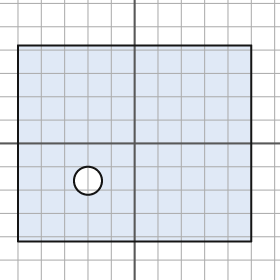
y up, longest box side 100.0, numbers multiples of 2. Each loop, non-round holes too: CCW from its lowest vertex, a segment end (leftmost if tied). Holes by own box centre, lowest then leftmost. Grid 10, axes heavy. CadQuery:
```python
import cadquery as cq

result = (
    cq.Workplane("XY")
    .moveTo(-50.0, -42.0)
    .lineTo(50.0, -42.0)
    .lineTo(50.0, 42.0)
    .lineTo(-50.0, 42.0)
    .close()
    .moveTo(-20.0, -16.0)
    .circle(6.0)
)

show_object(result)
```